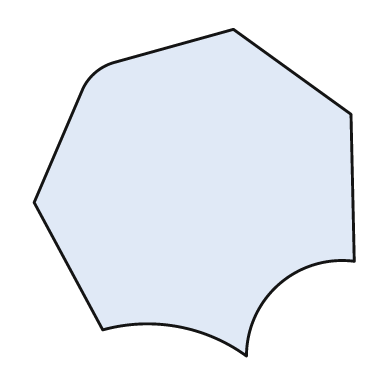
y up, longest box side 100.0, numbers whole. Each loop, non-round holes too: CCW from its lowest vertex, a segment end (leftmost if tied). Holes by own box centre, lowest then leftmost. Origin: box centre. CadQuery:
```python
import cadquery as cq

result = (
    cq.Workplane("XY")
    .moveTo(16.0, -50.0)
    .threePointArc((26.0, -28.0), (49.0, -21.0))
    .lineTo(48.0, 24.0)
    .lineTo(12.0, 50.0)
    .lineTo(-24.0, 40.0)
    .threePointArc((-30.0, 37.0), (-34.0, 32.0))
    .lineTo(-49.0, -3.0)
    .lineTo(-28.0, -42.0)
    .threePointArc((-5.0, -41.0), (16.0, -50.0))
    .close()
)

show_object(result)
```